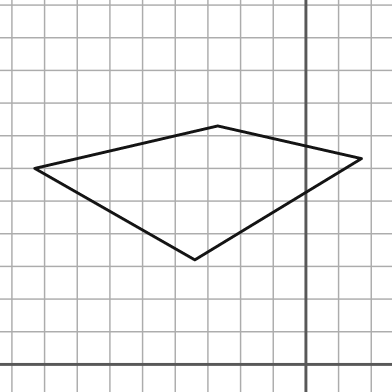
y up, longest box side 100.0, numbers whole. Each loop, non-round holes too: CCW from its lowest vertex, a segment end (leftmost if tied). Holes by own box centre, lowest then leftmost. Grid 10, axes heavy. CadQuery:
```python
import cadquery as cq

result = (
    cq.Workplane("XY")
    .moveTo(-34.0, 32.0)
    .lineTo(17.0, 63.0)
    .lineTo(-27.0, 73.0)
    .lineTo(-83.0, 60.0)
    .close()
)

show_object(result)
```